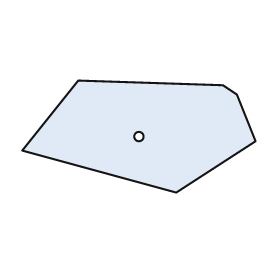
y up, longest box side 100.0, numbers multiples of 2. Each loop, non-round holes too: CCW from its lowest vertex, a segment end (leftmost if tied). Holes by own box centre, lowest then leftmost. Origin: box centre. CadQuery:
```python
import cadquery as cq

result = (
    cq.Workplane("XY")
    .moveTo(16.0, -24.0)
    .lineTo(50.0, -2.0)
    .lineTo(42.0, 18.0)
    .lineTo(36.0, 22.0)
    .lineTo(-26.0, 24.0)
    .lineTo(-50.0, -6.0)
    .close()
    .moveTo(0.0, 0.0)
    .circle(2.0)
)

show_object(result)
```